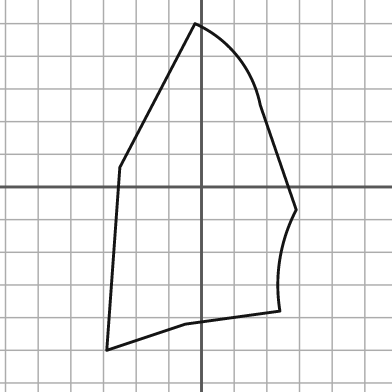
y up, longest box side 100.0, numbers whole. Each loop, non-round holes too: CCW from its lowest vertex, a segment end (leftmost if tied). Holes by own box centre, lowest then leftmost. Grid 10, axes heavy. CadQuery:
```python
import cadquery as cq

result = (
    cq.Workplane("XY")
    .moveTo(-29.0, -50.0)
    .lineTo(-5.0, -42.0)
    .lineTo(24.0, -38.0)
    .threePointArc((24.0, -22.0), (29.0, -7.0))
    .lineTo(18.0, 25.0)
    .threePointArc((11.0, 40.0), (-2.0, 50.0))
    .lineTo(-25.0, 6.0)
    .close()
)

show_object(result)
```